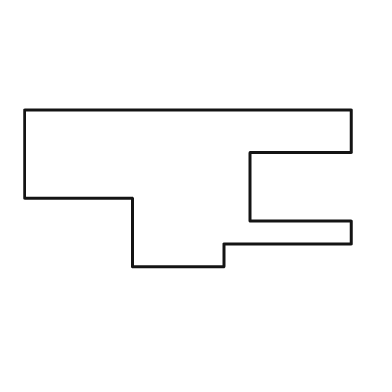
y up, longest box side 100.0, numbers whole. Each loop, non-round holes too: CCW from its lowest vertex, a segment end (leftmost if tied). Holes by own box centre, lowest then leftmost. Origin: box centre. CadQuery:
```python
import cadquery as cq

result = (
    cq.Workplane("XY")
    .moveTo(-17.0, -24.0)
    .lineTo(11.0, -24.0)
    .lineTo(11.0, -17.0)
    .lineTo(50.0, -17.0)
    .lineTo(50.0, -10.0)
    .lineTo(19.0, -10.0)
    .lineTo(19.0, 11.0)
    .lineTo(50.0, 11.0)
    .lineTo(50.0, 24.0)
    .lineTo(-50.0, 24.0)
    .lineTo(-50.0, -3.0)
    .lineTo(-17.0, -3.0)
    .close()
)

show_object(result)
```